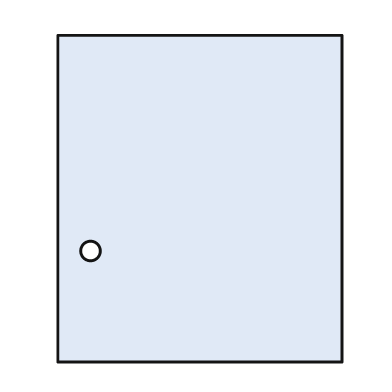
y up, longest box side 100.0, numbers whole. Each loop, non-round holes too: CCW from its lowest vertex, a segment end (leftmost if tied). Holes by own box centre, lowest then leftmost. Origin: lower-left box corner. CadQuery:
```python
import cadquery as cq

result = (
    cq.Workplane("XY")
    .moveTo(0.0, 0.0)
    .lineTo(87.0, 0.0)
    .lineTo(87.0, 100.0)
    .lineTo(0.0, 100.0)
    .close()
    .moveTo(10.0, 34.0)
    .circle(3.0)
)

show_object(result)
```